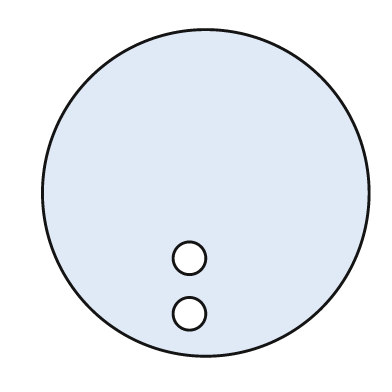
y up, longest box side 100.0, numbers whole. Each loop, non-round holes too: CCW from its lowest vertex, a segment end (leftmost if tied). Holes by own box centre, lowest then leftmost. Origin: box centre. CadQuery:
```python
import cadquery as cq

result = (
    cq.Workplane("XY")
    .moveTo(0.0, 0.0)
    .circle(50.0)
    .moveTo(-5.0, -37.0)
    .circle(5.0)
    .moveTo(-5.0, -20.0)
    .circle(5.0)
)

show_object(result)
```